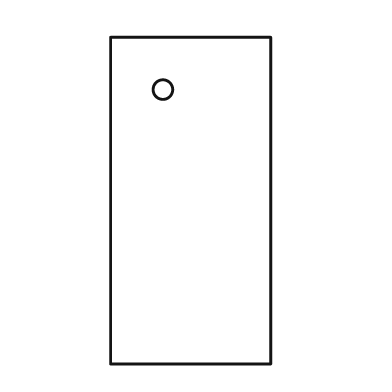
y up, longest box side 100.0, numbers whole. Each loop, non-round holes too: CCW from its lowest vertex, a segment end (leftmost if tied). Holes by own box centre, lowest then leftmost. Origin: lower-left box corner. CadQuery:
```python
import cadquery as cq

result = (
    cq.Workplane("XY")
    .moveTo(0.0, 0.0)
    .lineTo(49.0, 0.0)
    .lineTo(49.0, 100.0)
    .lineTo(0.0, 100.0)
    .close()
    .moveTo(16.0, 84.0)
    .circle(3.0)
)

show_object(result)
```